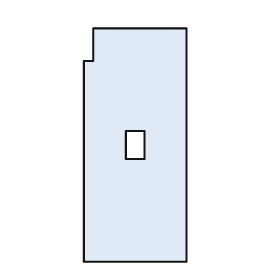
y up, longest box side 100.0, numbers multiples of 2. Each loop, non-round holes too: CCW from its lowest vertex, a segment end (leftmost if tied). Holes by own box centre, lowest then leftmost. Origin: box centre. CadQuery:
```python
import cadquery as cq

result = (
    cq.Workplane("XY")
    .moveTo(-22.0, -50.0)
    .lineTo(22.0, -50.0)
    .lineTo(22.0, 50.0)
    .lineTo(-18.0, 50.0)
    .lineTo(-18.0, 36.0)
    .lineTo(-22.0, 36.0)
    .close()
    .moveTo(-4.0, -6.0)
    .lineTo(4.0, -6.0)
    .lineTo(4.0, 6.0)
    .lineTo(-4.0, 6.0)
    .close()
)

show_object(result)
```